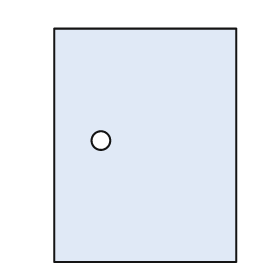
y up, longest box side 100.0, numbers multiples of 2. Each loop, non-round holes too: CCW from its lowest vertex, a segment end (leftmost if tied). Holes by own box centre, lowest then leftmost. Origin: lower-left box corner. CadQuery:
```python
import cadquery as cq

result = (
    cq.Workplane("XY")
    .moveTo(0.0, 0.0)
    .lineTo(78.0, 0.0)
    .lineTo(78.0, 100.0)
    .lineTo(0.0, 100.0)
    .close()
    .moveTo(20.0, 52.0)
    .circle(4.0)
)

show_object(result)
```